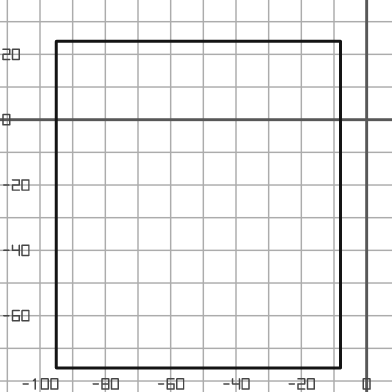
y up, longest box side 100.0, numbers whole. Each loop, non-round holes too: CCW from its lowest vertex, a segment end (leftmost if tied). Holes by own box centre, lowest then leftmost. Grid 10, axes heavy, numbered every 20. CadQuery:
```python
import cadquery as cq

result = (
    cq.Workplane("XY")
    .moveTo(-95.0, -76.0)
    .lineTo(-8.0, -76.0)
    .lineTo(-8.0, 24.0)
    .lineTo(-95.0, 24.0)
    .close()
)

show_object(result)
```